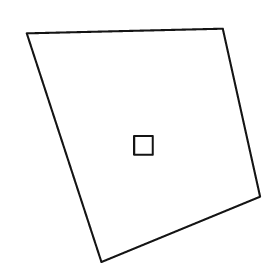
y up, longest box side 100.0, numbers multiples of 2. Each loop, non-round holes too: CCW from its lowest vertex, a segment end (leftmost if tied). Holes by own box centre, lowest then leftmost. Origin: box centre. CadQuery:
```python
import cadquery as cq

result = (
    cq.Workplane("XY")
    .moveTo(-18.0, -50.0)
    .lineTo(50.0, -22.0)
    .lineTo(34.0, 50.0)
    .lineTo(-50.0, 48.0)
    .close()
    .moveTo(-4.0, -4.0)
    .lineTo(4.0, -4.0)
    .lineTo(4.0, 4.0)
    .lineTo(-4.0, 4.0)
    .close()
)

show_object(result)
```